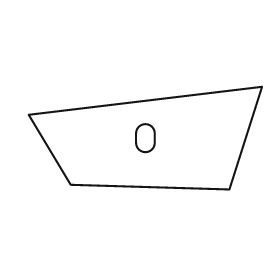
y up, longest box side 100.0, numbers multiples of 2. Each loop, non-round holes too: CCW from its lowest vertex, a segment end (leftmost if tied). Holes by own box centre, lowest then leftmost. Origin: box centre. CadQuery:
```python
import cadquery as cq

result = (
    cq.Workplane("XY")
    .moveTo(36.0, -22.0)
    .lineTo(50.0, 22.0)
    .lineTo(-50.0, 10.0)
    .lineTo(-32.0, -20.0)
    .close()
    .moveTo(-4.0, -2.0)
    .threePointArc((0.0, -6.0), (4.0, -2.0))
    .lineTo(4.0, 2.0)
    .threePointArc((0.0, 6.0), (-4.0, 2.0))
    .close()
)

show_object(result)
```